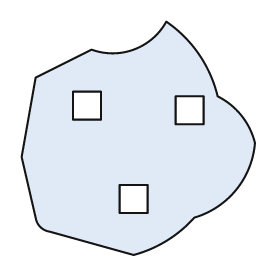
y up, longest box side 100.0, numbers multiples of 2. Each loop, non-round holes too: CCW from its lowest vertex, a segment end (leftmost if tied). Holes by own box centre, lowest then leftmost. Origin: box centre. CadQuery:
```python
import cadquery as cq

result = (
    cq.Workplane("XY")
    .moveTo(-2.0, -50.0)
    .threePointArc((12.0, -44.0), (24.0, -34.0))
    .threePointArc((42.0, -22.0), (50.0, -2.0))
    .threePointArc((44.0, 10.0), (34.0, 18.0))
    .threePointArc((26.0, 36.0), (12.0, 50.0))
    .threePointArc((-2.0, 38.0), (-20.0, 38.0))
    .lineTo(-44.0, 26.0)
    .lineTo(-50.0, -8.0)
    .lineTo(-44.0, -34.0)
    .threePointArc((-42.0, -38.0), (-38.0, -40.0))
    .close()
    .moveTo(-8.0, -32.0)
    .lineTo(4.0, -32.0)
    .lineTo(4.0, -20.0)
    .lineTo(-8.0, -20.0)
    .close()
    .moveTo(16.0, 6.0)
    .lineTo(28.0, 6.0)
    .lineTo(28.0, 18.0)
    .lineTo(16.0, 18.0)
    .close()
    .moveTo(-28.0, 8.0)
    .lineTo(-16.0, 8.0)
    .lineTo(-16.0, 20.0)
    .lineTo(-28.0, 20.0)
    .close()
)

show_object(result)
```